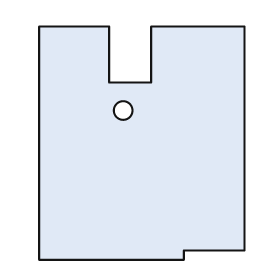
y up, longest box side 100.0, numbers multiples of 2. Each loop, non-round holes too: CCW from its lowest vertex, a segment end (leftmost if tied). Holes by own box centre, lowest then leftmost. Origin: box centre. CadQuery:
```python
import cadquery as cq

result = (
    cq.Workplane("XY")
    .moveTo(-44.0, -50.0)
    .lineTo(18.0, -50.0)
    .lineTo(18.0, -46.0)
    .lineTo(44.0, -46.0)
    .lineTo(44.0, 50.0)
    .lineTo(4.0, 50.0)
    .lineTo(4.0, 26.0)
    .lineTo(-14.0, 26.0)
    .lineTo(-14.0, 50.0)
    .lineTo(-44.0, 50.0)
    .close()
    .moveTo(-8.0, 14.0)
    .circle(4.0)
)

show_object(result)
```